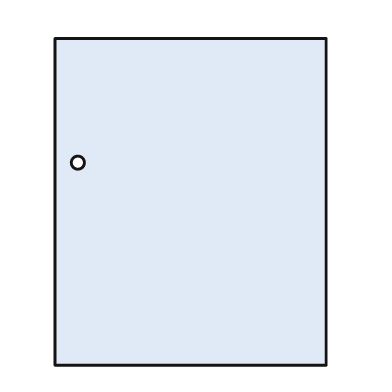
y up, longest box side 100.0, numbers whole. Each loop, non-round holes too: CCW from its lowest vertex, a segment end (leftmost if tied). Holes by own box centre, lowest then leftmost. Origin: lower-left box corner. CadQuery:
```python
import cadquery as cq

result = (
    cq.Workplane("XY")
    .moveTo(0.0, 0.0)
    .lineTo(83.0, 0.0)
    .lineTo(83.0, 100.0)
    .lineTo(0.0, 100.0)
    .close()
    .moveTo(7.0, 62.0)
    .circle(2.0)
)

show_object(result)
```